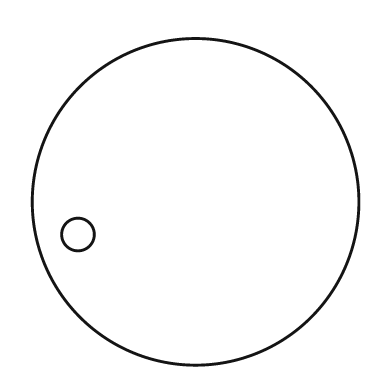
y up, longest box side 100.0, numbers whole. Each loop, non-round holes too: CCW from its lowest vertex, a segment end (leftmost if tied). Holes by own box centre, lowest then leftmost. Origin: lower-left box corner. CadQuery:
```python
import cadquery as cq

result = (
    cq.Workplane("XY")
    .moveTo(50.0, 50.0)
    .circle(50.0)
    .moveTo(14.0, 40.0)
    .circle(5.0)
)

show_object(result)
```